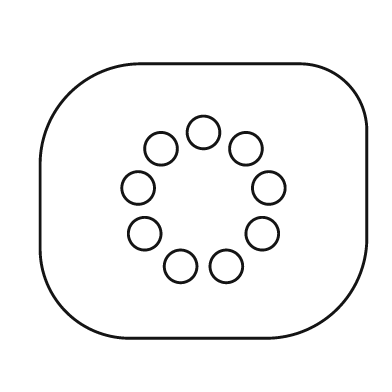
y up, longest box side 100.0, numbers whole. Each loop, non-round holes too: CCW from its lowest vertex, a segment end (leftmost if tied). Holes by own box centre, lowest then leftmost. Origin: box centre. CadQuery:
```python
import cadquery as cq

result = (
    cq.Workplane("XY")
    .moveTo(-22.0, -42.0)
    .lineTo(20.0, -42.0)
    .threePointArc((41.0, -33.0), (50.0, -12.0))
    .lineTo(50.0, 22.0)
    .threePointArc((44.0, 36.0), (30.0, 42.0))
    .lineTo(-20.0, 42.0)
    .threePointArc((-41.0, 33.0), (-50.0, 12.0))
    .lineTo(-50.0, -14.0)
    .threePointArc((-42.0, -34.0), (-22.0, -42.0))
    .close()
    .moveTo(-7.0, -20.0)
    .circle(5.0)
    .moveTo(7.0, -20.0)
    .circle(5.0)
    .moveTo(-18.0, -10.0)
    .circle(5.0)
    .moveTo(18.0, -10.0)
    .circle(5.0)
    .moveTo(-20.0, 4.0)
    .circle(5.0)
    .moveTo(20.0, 4.0)
    .circle(5.0)
    .moveTo(-13.0, 16.0)
    .circle(5.0)
    .moveTo(13.0, 16.0)
    .circle(5.0)
    .moveTo(0.0, 21.0)
    .circle(5.0)
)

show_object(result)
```